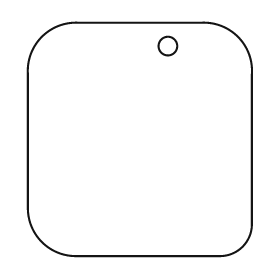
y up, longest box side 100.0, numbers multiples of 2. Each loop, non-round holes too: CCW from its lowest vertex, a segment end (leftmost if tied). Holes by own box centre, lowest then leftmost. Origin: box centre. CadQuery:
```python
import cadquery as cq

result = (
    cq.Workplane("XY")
    .moveTo(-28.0, -50.0)
    .lineTo(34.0, -50.0)
    .threePointArc((44.0, -46.0), (48.0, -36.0))
    .lineTo(48.0, 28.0)
    .threePointArc((42.0, 44.0), (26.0, 50.0))
    .lineTo(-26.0, 50.0)
    .threePointArc((-42.0, 44.0), (-48.0, 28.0))
    .lineTo(-48.0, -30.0)
    .threePointArc((-42.0, -44.0), (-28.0, -50.0))
    .close()
    .moveTo(12.0, 40.0)
    .circle(4.0)
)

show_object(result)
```